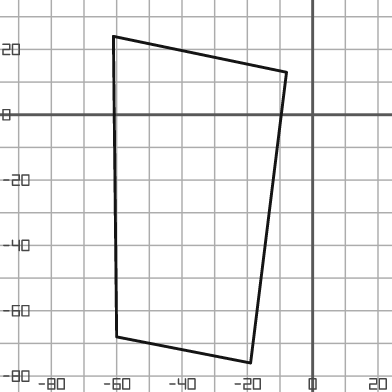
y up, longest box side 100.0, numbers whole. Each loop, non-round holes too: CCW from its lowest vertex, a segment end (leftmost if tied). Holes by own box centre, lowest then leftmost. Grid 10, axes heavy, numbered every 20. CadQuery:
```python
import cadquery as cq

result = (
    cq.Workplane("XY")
    .moveTo(-19.0, -76.0)
    .lineTo(-8.0, 13.0)
    .lineTo(-61.0, 24.0)
    .lineTo(-60.0, -68.0)
    .close()
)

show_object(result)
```